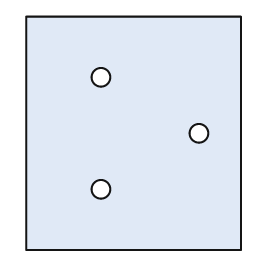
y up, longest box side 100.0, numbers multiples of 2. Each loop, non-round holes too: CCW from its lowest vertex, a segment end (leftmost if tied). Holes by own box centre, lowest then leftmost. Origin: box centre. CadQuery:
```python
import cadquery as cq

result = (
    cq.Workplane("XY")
    .moveTo(-46.0, -50.0)
    .lineTo(46.0, -50.0)
    .lineTo(46.0, 50.0)
    .lineTo(-46.0, 50.0)
    .close()
    .moveTo(-14.0, -24.0)
    .circle(4.0)
    .moveTo(28.0, 0.0)
    .circle(4.0)
    .moveTo(-14.0, 24.0)
    .circle(4.0)
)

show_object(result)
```